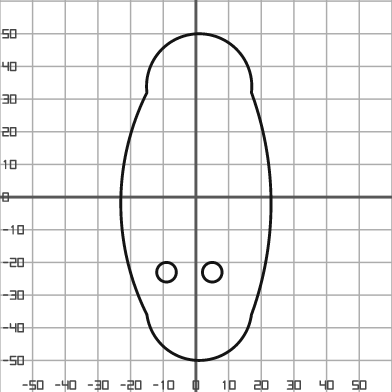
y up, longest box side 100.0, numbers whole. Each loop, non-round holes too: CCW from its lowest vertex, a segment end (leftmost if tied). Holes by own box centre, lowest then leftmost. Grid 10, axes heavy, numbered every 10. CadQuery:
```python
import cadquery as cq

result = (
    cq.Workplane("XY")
    .moveTo(-15.0, -36.0)
    .threePointArc((1.0, -50.0), (17.0, -36.0))
    .threePointArc((23.0, -2.0), (17.0, 32.0))
    .threePointArc((1.0, 50.0), (-15.0, 32.0))
    .threePointArc((-23.0, -2.0), (-15.0, -36.0))
    .close()
    .moveTo(-9.0, -23.0)
    .circle(3.0)
    .moveTo(5.0, -23.0)
    .circle(3.0)
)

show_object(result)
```